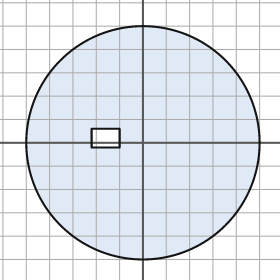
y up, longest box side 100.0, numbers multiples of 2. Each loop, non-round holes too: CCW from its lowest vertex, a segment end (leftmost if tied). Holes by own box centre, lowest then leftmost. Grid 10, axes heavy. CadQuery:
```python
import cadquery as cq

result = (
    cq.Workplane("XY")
    .moveTo(0.0, 0.0)
    .circle(50.0)
    .moveTo(-22.0, -2.0)
    .lineTo(-10.0, -2.0)
    .lineTo(-10.0, 6.0)
    .lineTo(-22.0, 6.0)
    .close()
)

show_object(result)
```